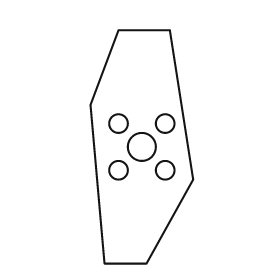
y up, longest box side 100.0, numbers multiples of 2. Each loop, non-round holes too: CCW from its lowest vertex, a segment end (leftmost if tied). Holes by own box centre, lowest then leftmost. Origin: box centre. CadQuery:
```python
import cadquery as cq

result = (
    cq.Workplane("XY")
    .moveTo(-16.0, -50.0)
    .lineTo(2.0, -50.0)
    .lineTo(22.0, -14.0)
    .lineTo(12.0, 50.0)
    .lineTo(-10.0, 50.0)
    .lineTo(-22.0, 18.0)
    .close()
    .moveTo(-10.0, -10.0)
    .circle(4.0)
    .moveTo(10.0, -10.0)
    .circle(4.0)
    .moveTo(0.0, 0.0)
    .circle(6.0)
    .moveTo(-10.0, 10.0)
    .circle(4.0)
    .moveTo(10.0, 10.0)
    .circle(4.0)
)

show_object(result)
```